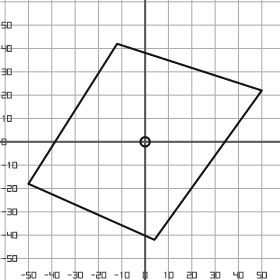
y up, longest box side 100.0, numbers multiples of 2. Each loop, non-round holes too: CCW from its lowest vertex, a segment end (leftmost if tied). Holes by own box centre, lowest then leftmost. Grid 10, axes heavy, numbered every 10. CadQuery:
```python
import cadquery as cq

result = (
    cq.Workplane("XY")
    .moveTo(4.0, -42.0)
    .lineTo(50.0, 22.0)
    .lineTo(-12.0, 42.0)
    .lineTo(-50.0, -18.0)
    .close()
    .moveTo(0.0, 0.0)
    .circle(2.0)
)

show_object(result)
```